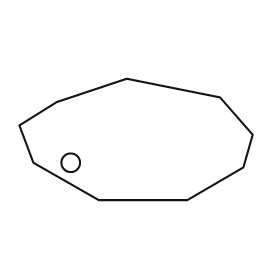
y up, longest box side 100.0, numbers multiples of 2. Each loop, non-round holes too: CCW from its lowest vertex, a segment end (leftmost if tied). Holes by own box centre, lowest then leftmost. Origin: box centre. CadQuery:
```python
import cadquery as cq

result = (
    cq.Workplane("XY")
    .moveTo(-16.0, -26.0)
    .lineTo(22.0, -26.0)
    .lineTo(46.0, -12.0)
    .lineTo(50.0, 2.0)
    .lineTo(36.0, 18.0)
    .lineTo(-4.0, 26.0)
    .lineTo(-34.0, 16.0)
    .lineTo(-50.0, 6.0)
    .lineTo(-44.0, -10.0)
    .close()
    .moveTo(-28.0, -10.0)
    .circle(4.0)
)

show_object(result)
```